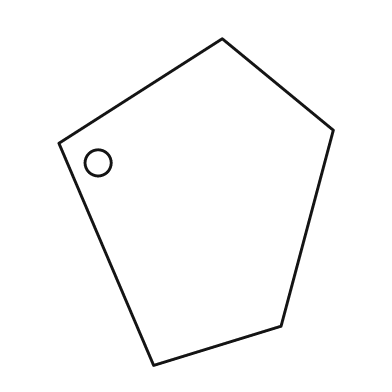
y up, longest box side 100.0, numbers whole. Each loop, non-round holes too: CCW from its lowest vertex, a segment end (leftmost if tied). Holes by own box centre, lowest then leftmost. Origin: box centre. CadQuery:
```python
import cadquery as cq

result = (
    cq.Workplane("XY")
    .moveTo(-13.0, -50.0)
    .lineTo(26.0, -38.0)
    .lineTo(42.0, 22.0)
    .lineTo(8.0, 50.0)
    .lineTo(-42.0, 18.0)
    .close()
    .moveTo(-30.0, 12.0)
    .circle(4.0)
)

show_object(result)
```